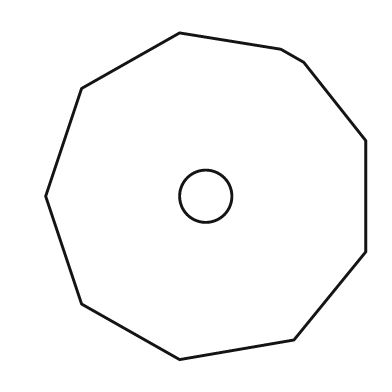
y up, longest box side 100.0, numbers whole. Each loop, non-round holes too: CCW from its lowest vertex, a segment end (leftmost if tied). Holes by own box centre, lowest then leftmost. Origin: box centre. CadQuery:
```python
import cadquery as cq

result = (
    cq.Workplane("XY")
    .moveTo(-8.0, -50.0)
    .lineTo(27.0, -44.0)
    .lineTo(49.0, -17.0)
    .lineTo(49.0, 17.0)
    .lineTo(30.0, 41.0)
    .lineTo(23.0, 45.0)
    .lineTo(-8.0, 50.0)
    .lineTo(-38.0, 33.0)
    .lineTo(-49.0, 0.0)
    .lineTo(-38.0, -33.0)
    .close()
    .moveTo(0.0, 0.0)
    .circle(8.0)
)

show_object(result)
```